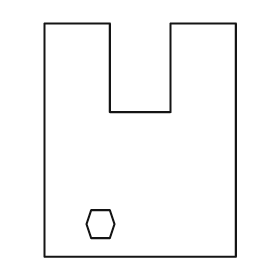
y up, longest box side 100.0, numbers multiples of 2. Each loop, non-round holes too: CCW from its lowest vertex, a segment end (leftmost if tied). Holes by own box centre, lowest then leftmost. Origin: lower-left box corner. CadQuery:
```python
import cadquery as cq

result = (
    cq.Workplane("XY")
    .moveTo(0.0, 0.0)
    .lineTo(82.0, 0.0)
    .lineTo(82.0, 100.0)
    .lineTo(54.0, 100.0)
    .lineTo(54.0, 62.0)
    .lineTo(28.0, 62.0)
    .lineTo(28.0, 100.0)
    .lineTo(0.0, 100.0)
    .close()
    .moveTo(20.0, 8.0)
    .lineTo(28.0, 8.0)
    .lineTo(30.0, 14.0)
    .lineTo(28.0, 20.0)
    .lineTo(20.0, 20.0)
    .lineTo(18.0, 14.0)
    .close()
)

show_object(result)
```